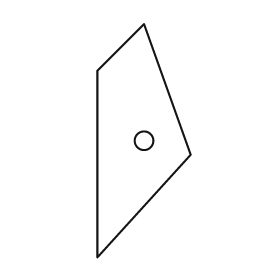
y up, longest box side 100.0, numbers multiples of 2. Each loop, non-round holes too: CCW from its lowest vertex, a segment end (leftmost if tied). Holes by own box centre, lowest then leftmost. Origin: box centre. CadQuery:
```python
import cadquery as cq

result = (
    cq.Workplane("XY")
    .moveTo(-20.0, -50.0)
    .lineTo(20.0, -6.0)
    .lineTo(0.0, 50.0)
    .lineTo(-20.0, 30.0)
    .close()
    .moveTo(0.0, 0.0)
    .circle(4.0)
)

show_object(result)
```